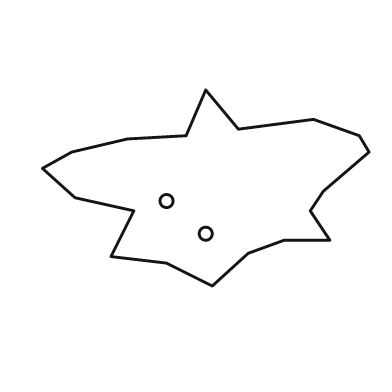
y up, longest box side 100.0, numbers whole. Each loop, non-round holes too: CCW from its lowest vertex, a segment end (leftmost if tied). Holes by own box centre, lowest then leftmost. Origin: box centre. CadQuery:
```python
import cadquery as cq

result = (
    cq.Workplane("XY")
    .moveTo(2.0, -30.0)
    .lineTo(13.0, -20.0)
    .lineTo(24.0, -16.0)
    .lineTo(38.0, -16.0)
    .lineTo(32.0, -7.0)
    .lineTo(36.0, -1.0)
    .lineTo(50.0, 11.0)
    .lineTo(47.0, 16.0)
    .lineTo(33.0, 21.0)
    .lineTo(10.0, 18.0)
    .lineTo(0.0, 30.0)
    .lineTo(-6.0, 16.0)
    .lineTo(-24.0, 15.0)
    .lineTo(-41.0, 11.0)
    .lineTo(-50.0, 6.0)
    .lineTo(-40.0, -3.0)
    .lineTo(-22.0, -7.0)
    .lineTo(-29.0, -21.0)
    .lineTo(-12.0, -23.0)
    .close()
    .moveTo(0.0, -14.0)
    .circle(2.0)
    .moveTo(-12.0, -4.0)
    .circle(2.0)
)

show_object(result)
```